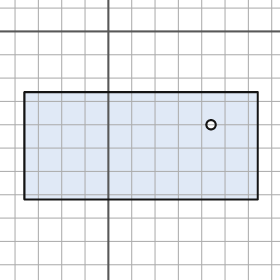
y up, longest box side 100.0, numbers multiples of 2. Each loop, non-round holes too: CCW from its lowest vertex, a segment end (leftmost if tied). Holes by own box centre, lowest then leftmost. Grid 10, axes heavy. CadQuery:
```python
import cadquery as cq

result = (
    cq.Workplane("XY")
    .moveTo(-36.0, -72.0)
    .lineTo(64.0, -72.0)
    .lineTo(64.0, -26.0)
    .lineTo(-36.0, -26.0)
    .close()
    .moveTo(44.0, -40.0)
    .circle(2.0)
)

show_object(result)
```